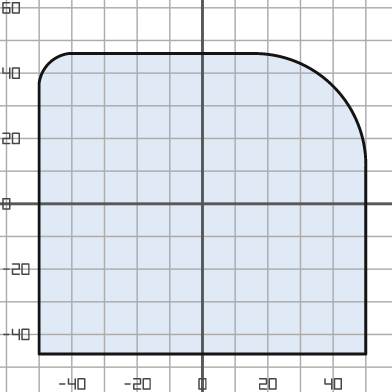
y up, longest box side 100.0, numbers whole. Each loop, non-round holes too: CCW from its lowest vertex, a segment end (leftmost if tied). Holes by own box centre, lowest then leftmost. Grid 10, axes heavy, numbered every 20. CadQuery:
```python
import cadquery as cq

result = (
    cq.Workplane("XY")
    .moveTo(-50.0, -46.0)
    .lineTo(50.0, -46.0)
    .lineTo(50.0, 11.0)
    .threePointArc((40.0, 36.0), (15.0, 46.0))
    .lineTo(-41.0, 46.0)
    .threePointArc((-47.0, 43.0), (-50.0, 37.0))
    .close()
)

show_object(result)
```